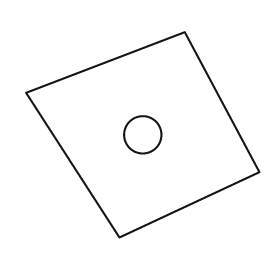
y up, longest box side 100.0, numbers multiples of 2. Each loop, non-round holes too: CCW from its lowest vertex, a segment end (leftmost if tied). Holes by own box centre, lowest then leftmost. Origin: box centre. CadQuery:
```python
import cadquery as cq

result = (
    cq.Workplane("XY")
    .moveTo(-10.0, -44.0)
    .lineTo(50.0, -16.0)
    .lineTo(18.0, 44.0)
    .lineTo(-50.0, 18.0)
    .close()
    .moveTo(0.0, 0.0)
    .circle(8.0)
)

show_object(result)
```